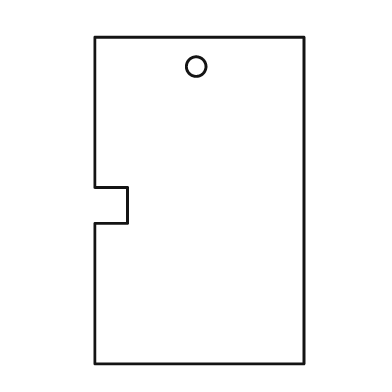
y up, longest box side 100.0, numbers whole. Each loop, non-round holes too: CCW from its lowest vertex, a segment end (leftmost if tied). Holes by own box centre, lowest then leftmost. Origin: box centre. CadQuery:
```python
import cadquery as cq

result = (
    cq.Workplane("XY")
    .moveTo(-32.0, -50.0)
    .lineTo(32.0, -50.0)
    .lineTo(32.0, 50.0)
    .lineTo(-32.0, 50.0)
    .lineTo(-32.0, 4.0)
    .lineTo(-22.0, 4.0)
    .lineTo(-22.0, -7.0)
    .lineTo(-32.0, -7.0)
    .close()
    .moveTo(-1.0, 41.0)
    .circle(3.0)
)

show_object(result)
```